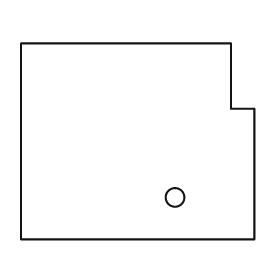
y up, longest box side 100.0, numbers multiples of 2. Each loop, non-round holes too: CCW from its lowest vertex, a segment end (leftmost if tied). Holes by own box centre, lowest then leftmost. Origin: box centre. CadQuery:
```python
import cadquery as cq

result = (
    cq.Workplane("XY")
    .moveTo(-50.0, -42.0)
    .lineTo(50.0, -42.0)
    .lineTo(50.0, 14.0)
    .lineTo(40.0, 14.0)
    .lineTo(40.0, 42.0)
    .lineTo(-50.0, 42.0)
    .close()
    .moveTo(16.0, -24.0)
    .circle(4.0)
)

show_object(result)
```